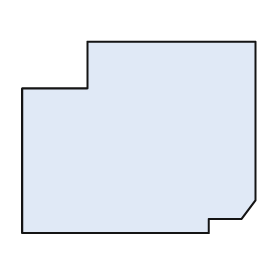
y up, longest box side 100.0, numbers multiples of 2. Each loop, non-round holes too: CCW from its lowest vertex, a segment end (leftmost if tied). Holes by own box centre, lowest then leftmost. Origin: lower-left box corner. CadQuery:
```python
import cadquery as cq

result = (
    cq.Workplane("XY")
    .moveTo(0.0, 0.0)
    .lineTo(80.0, 0.0)
    .lineTo(80.0, 6.0)
    .lineTo(94.0, 6.0)
    .lineTo(100.0, 14.0)
    .lineTo(100.0, 82.0)
    .lineTo(28.0, 82.0)
    .lineTo(28.0, 62.0)
    .lineTo(0.0, 62.0)
    .close()
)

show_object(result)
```